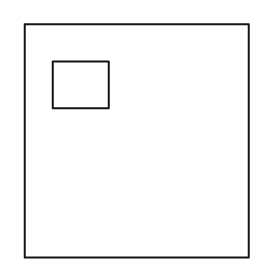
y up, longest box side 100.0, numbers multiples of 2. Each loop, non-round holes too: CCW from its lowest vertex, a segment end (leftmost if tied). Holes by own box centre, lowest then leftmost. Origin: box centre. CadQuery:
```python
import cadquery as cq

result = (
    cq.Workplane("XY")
    .moveTo(-48.0, -50.0)
    .lineTo(48.0, -50.0)
    .lineTo(48.0, 50.0)
    .lineTo(-48.0, 50.0)
    .close()
    .moveTo(-36.0, 14.0)
    .lineTo(-12.0, 14.0)
    .lineTo(-12.0, 34.0)
    .lineTo(-36.0, 34.0)
    .close()
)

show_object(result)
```